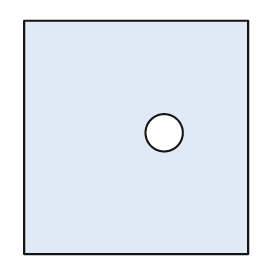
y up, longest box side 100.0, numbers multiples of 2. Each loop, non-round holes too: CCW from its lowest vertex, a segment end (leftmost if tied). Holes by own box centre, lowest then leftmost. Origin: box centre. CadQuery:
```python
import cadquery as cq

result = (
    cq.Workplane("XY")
    .moveTo(-48.0, -50.0)
    .lineTo(48.0, -50.0)
    .lineTo(48.0, 50.0)
    .lineTo(-48.0, 50.0)
    .close()
    .moveTo(12.0, 2.0)
    .circle(8.0)
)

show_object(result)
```